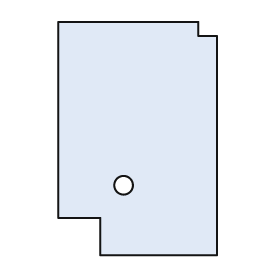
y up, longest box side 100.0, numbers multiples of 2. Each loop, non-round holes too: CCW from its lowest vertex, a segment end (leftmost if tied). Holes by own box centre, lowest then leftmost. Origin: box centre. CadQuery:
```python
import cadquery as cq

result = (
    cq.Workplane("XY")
    .moveTo(-16.0, -50.0)
    .lineTo(34.0, -50.0)
    .lineTo(34.0, 44.0)
    .lineTo(26.0, 44.0)
    .lineTo(26.0, 50.0)
    .lineTo(-34.0, 50.0)
    .lineTo(-34.0, -34.0)
    .lineTo(-16.0, -34.0)
    .close()
    .moveTo(-6.0, -20.0)
    .circle(4.0)
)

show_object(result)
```